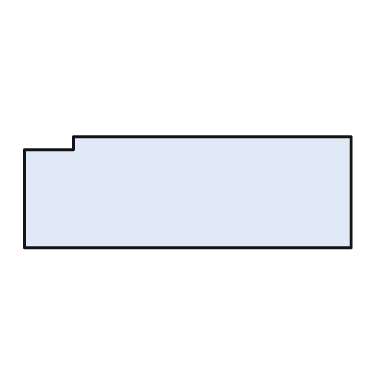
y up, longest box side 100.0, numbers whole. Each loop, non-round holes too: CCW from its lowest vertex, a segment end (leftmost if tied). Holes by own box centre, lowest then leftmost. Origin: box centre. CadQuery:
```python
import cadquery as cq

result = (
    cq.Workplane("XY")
    .moveTo(-50.0, -17.0)
    .lineTo(50.0, -17.0)
    .lineTo(50.0, 17.0)
    .lineTo(-35.0, 17.0)
    .lineTo(-35.0, 13.0)
    .lineTo(-50.0, 13.0)
    .close()
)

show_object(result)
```